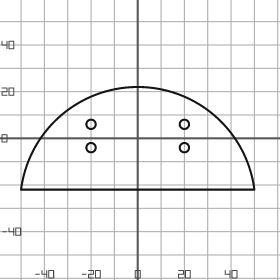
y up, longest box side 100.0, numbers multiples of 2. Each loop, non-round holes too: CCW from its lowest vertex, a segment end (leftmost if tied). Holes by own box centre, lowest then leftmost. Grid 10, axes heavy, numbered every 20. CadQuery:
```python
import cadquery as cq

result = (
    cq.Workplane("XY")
    .moveTo(-50.0, -22.0)
    .lineTo(50.0, -22.0)
    .threePointArc((0.0, 22.0), (-50.0, -22.0))
    .close()
    .moveTo(-20.0, -4.0)
    .circle(2.0)
    .moveTo(20.0, -4.0)
    .circle(2.0)
    .moveTo(-20.0, 6.0)
    .circle(2.0)
    .moveTo(20.0, 6.0)
    .circle(2.0)
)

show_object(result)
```